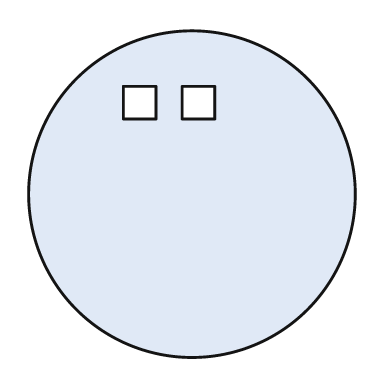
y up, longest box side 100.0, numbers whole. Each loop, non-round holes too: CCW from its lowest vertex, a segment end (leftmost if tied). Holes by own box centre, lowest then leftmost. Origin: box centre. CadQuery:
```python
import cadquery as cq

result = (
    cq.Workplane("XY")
    .moveTo(0.0, 0.0)
    .circle(50.0)
    .moveTo(-21.0, 23.0)
    .lineTo(-11.0, 23.0)
    .lineTo(-11.0, 33.0)
    .lineTo(-21.0, 33.0)
    .close()
    .moveTo(-3.0, 23.0)
    .lineTo(7.0, 23.0)
    .lineTo(7.0, 33.0)
    .lineTo(-3.0, 33.0)
    .close()
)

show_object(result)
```